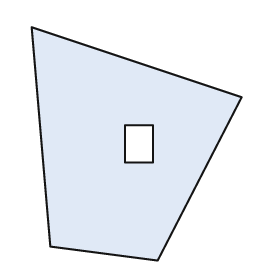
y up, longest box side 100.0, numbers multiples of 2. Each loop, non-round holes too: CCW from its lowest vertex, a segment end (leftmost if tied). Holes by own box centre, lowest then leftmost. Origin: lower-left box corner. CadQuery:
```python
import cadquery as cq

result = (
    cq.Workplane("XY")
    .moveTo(54.0, 0.0)
    .lineTo(90.0, 70.0)
    .lineTo(0.0, 100.0)
    .lineTo(8.0, 6.0)
    .close()
    .moveTo(40.0, 42.0)
    .lineTo(52.0, 42.0)
    .lineTo(52.0, 58.0)
    .lineTo(40.0, 58.0)
    .close()
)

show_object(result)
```